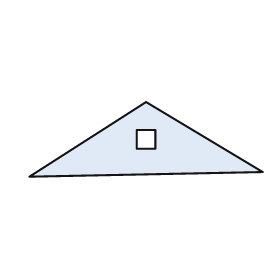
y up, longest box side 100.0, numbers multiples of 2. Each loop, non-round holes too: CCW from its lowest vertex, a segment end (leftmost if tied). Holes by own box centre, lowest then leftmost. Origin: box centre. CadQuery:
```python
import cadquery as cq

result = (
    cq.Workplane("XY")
    .moveTo(-50.0, -16.0)
    .lineTo(50.0, -14.0)
    .lineTo(0.0, 16.0)
    .close()
    .moveTo(-4.0, -4.0)
    .lineTo(4.0, -4.0)
    .lineTo(4.0, 4.0)
    .lineTo(-4.0, 4.0)
    .close()
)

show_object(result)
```